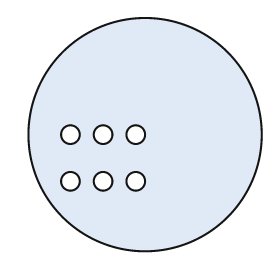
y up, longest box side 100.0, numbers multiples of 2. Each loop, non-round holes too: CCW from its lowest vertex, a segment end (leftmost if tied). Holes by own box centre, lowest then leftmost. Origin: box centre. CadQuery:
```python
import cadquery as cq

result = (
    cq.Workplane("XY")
    .moveTo(0.0, 0.0)
    .circle(50.0)
    .moveTo(-32.0, -20.0)
    .circle(4.0)
    .moveTo(-18.0, -20.0)
    .circle(4.0)
    .moveTo(-4.0, -20.0)
    .circle(4.0)
    .moveTo(-32.0, 0.0)
    .circle(4.0)
    .moveTo(-18.0, 0.0)
    .circle(4.0)
    .moveTo(-4.0, 0.0)
    .circle(4.0)
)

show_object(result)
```